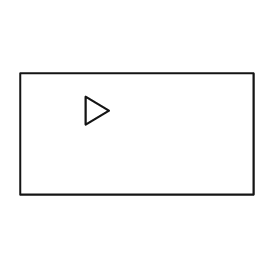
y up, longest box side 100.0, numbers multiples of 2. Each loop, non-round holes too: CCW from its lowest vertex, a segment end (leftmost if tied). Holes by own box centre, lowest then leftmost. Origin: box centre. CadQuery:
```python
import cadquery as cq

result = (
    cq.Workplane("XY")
    .moveTo(-50.0, -26.0)
    .lineTo(50.0, -26.0)
    .lineTo(50.0, 26.0)
    .lineTo(-50.0, 26.0)
    .close()
    .moveTo(-22.0, 4.0)
    .lineTo(-12.0, 10.0)
    .lineTo(-22.0, 16.0)
    .close()
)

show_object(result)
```